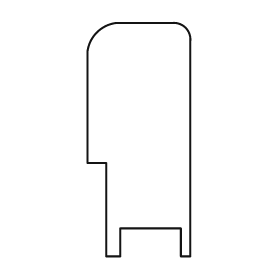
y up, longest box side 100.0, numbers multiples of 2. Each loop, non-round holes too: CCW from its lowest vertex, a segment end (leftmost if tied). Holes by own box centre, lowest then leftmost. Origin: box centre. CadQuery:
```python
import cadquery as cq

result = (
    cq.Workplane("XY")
    .moveTo(-14.0, -50.0)
    .lineTo(-8.0, -50.0)
    .lineTo(-8.0, -38.0)
    .lineTo(18.0, -38.0)
    .lineTo(18.0, -50.0)
    .lineTo(22.0, -50.0)
    .lineTo(22.0, 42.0)
    .threePointArc((20.0, 48.0), (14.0, 50.0))
    .lineTo(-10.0, 50.0)
    .threePointArc((-18.0, 46.0), (-22.0, 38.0))
    .lineTo(-22.0, -10.0)
    .lineTo(-14.0, -10.0)
    .close()
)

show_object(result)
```